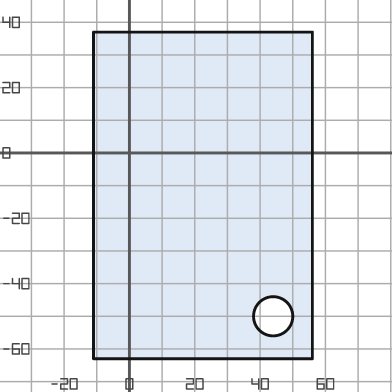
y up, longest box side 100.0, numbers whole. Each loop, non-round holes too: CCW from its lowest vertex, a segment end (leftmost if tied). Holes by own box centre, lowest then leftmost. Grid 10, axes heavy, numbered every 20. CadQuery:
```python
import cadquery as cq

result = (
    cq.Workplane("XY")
    .moveTo(-11.0, -63.0)
    .lineTo(56.0, -63.0)
    .lineTo(56.0, 37.0)
    .lineTo(-11.0, 37.0)
    .close()
    .moveTo(44.0, -50.0)
    .circle(6.0)
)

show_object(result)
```